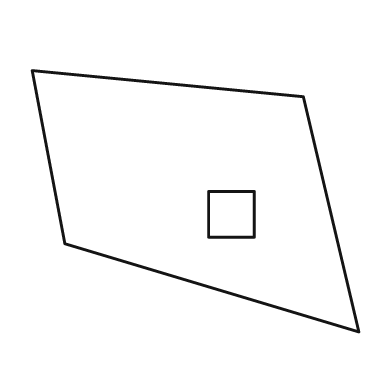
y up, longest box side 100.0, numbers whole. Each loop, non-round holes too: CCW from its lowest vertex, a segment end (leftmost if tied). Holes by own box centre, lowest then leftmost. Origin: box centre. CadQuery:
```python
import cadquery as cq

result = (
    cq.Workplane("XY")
    .moveTo(50.0, -40.0)
    .lineTo(33.0, 32.0)
    .lineTo(-50.0, 40.0)
    .lineTo(-40.0, -13.0)
    .close()
    .moveTo(4.0, -11.0)
    .lineTo(18.0, -11.0)
    .lineTo(18.0, 3.0)
    .lineTo(4.0, 3.0)
    .close()
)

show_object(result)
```